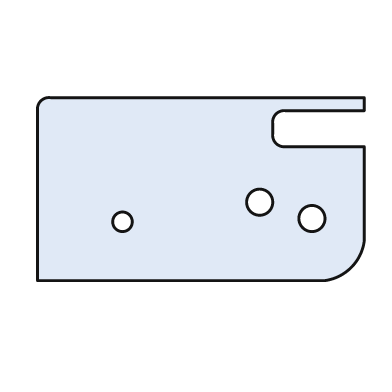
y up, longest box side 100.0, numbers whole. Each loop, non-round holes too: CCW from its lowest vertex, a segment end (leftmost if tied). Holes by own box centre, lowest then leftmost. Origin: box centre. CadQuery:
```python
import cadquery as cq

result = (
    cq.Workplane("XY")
    .moveTo(-50.0, -28.0)
    .lineTo(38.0, -28.0)
    .threePointArc((46.0, -24.0), (50.0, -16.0))
    .lineTo(50.0, 13.0)
    .lineTo(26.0, 13.0)
    .threePointArc((23.0, 14.0), (22.0, 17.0))
    .lineTo(22.0, 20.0)
    .threePointArc((23.0, 23.0), (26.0, 24.0))
    .lineTo(50.0, 24.0)
    .lineTo(50.0, 28.0)
    .lineTo(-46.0, 28.0)
    .threePointArc((-49.0, 27.0), (-50.0, 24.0))
    .close()
    .moveTo(-24.0, -10.0)
    .circle(3.0)
    .moveTo(34.0, -9.0)
    .circle(4.0)
    .moveTo(18.0, -4.0)
    .circle(4.0)
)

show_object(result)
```